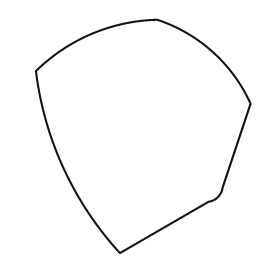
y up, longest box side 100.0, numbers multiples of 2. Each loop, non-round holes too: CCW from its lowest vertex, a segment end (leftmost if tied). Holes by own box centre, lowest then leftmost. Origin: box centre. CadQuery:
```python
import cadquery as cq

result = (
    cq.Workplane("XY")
    .moveTo(-10.0, -50.0)
    .lineTo(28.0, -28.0)
    .threePointArc((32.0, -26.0), (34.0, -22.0))
    .lineTo(46.0, 14.0)
    .threePointArc((30.0, 36.0), (6.0, 50.0))
    .threePointArc((-22.0, 44.0), (-46.0, 28.0))
    .threePointArc((-34.0, -14.0), (-10.0, -50.0))
    .close()
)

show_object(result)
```